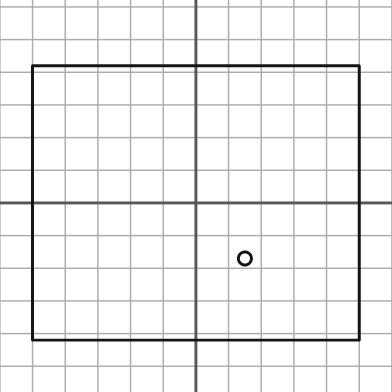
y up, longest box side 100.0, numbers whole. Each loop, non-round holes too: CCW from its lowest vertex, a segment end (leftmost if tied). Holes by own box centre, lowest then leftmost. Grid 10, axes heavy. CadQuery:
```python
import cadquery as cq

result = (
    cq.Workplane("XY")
    .moveTo(-50.0, -42.0)
    .lineTo(50.0, -42.0)
    .lineTo(50.0, 42.0)
    .lineTo(-50.0, 42.0)
    .close()
    .moveTo(15.0, -17.0)
    .circle(2.0)
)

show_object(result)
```